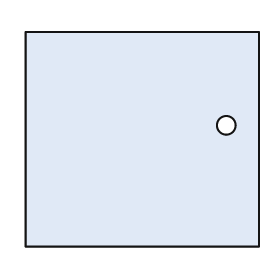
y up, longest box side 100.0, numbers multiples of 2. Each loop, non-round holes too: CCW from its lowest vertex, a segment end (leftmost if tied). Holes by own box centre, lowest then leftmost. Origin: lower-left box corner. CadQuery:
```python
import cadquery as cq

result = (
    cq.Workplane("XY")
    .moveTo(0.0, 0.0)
    .lineTo(100.0, 0.0)
    .lineTo(100.0, 92.0)
    .lineTo(0.0, 92.0)
    .close()
    .moveTo(86.0, 52.0)
    .circle(4.0)
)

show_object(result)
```